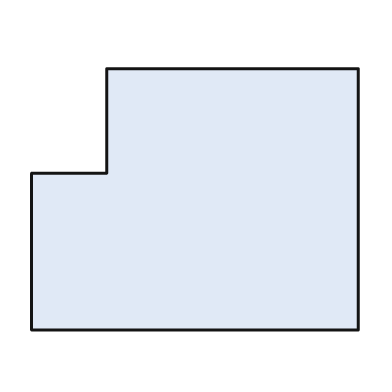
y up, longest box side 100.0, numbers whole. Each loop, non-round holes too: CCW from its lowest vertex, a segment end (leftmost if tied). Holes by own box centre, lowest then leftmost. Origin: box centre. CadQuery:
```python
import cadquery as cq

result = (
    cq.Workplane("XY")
    .moveTo(-50.0, -40.0)
    .lineTo(50.0, -40.0)
    .lineTo(50.0, 40.0)
    .lineTo(-27.0, 40.0)
    .lineTo(-27.0, 8.0)
    .lineTo(-50.0, 8.0)
    .close()
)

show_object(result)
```